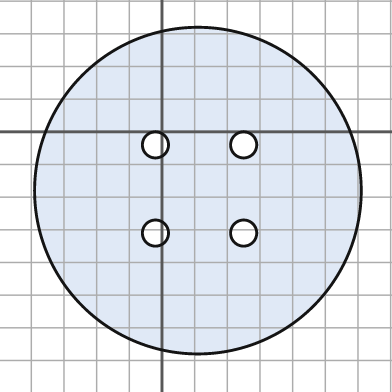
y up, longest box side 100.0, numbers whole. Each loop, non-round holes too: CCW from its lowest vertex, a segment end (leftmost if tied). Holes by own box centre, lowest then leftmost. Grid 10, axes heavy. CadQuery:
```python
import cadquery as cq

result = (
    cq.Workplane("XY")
    .moveTo(11.0, -18.0)
    .circle(50.0)
    .moveTo(-2.0, -31.0)
    .circle(4.0)
    .moveTo(25.0, -31.0)
    .circle(4.0)
    .moveTo(-2.0, -4.0)
    .circle(4.0)
    .moveTo(25.0, -4.0)
    .circle(4.0)
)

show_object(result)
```